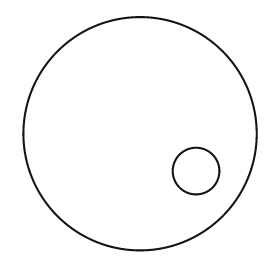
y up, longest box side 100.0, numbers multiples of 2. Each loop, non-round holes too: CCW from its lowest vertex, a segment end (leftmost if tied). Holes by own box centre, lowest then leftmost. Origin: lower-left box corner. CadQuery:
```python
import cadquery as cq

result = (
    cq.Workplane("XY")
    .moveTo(50.0, 50.0)
    .circle(50.0)
    .moveTo(74.0, 34.0)
    .circle(10.0)
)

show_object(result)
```